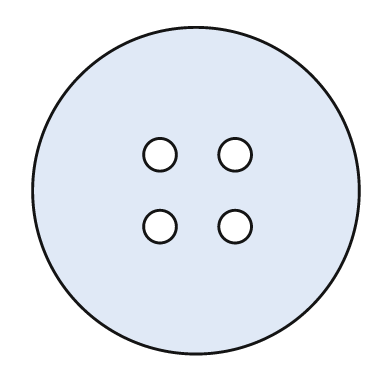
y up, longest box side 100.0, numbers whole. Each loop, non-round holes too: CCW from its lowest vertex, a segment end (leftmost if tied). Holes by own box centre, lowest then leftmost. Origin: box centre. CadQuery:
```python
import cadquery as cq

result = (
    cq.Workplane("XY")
    .moveTo(0.0, 0.0)
    .circle(50.0)
    .moveTo(-11.0, -11.0)
    .circle(5.0)
    .moveTo(12.0, -11.0)
    .circle(5.0)
    .moveTo(-11.0, 11.0)
    .circle(5.0)
    .moveTo(12.0, 11.0)
    .circle(5.0)
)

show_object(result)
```